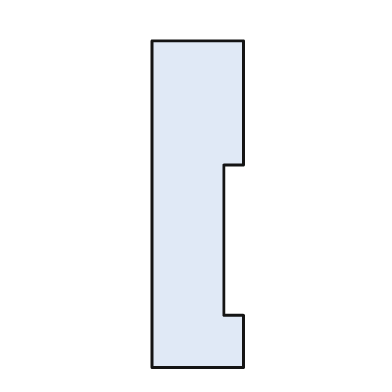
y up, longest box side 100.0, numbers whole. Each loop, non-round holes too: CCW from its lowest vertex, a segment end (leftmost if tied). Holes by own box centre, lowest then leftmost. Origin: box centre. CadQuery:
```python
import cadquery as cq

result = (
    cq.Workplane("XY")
    .moveTo(-14.0, -50.0)
    .lineTo(14.0, -50.0)
    .lineTo(14.0, -34.0)
    .lineTo(8.0, -34.0)
    .lineTo(8.0, 12.0)
    .lineTo(14.0, 12.0)
    .lineTo(14.0, 50.0)
    .lineTo(-14.0, 50.0)
    .close()
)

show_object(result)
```